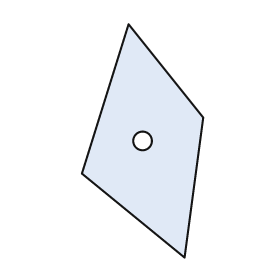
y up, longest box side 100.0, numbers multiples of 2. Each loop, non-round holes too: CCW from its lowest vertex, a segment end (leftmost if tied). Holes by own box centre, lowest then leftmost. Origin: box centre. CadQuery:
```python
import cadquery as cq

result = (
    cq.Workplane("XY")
    .moveTo(18.0, -50.0)
    .lineTo(26.0, 10.0)
    .lineTo(-6.0, 50.0)
    .lineTo(-26.0, -14.0)
    .close()
    .moveTo(0.0, 0.0)
    .circle(4.0)
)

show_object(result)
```